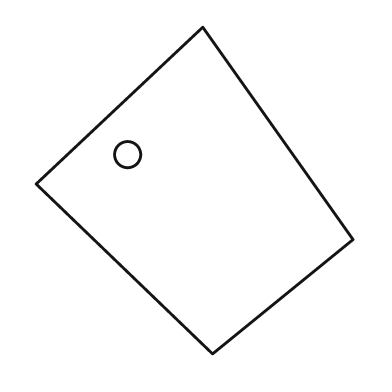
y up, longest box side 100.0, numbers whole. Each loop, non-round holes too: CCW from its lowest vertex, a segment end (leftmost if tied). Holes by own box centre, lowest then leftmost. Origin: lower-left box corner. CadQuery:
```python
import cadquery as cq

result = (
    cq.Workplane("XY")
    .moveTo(54.0, 0.0)
    .lineTo(97.0, 35.0)
    .lineTo(51.0, 100.0)
    .lineTo(0.0, 52.0)
    .close()
    .moveTo(28.0, 61.0)
    .circle(4.0)
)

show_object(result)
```